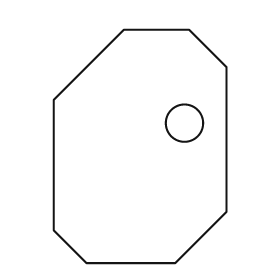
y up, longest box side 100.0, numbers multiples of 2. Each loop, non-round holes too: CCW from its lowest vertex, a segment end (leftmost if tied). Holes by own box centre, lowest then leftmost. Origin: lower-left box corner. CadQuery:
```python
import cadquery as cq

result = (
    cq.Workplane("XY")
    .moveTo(14.0, 0.0)
    .lineTo(52.0, 0.0)
    .lineTo(74.0, 22.0)
    .lineTo(74.0, 84.0)
    .lineTo(58.0, 100.0)
    .lineTo(30.0, 100.0)
    .lineTo(0.0, 70.0)
    .lineTo(0.0, 14.0)
    .close()
    .moveTo(56.0, 60.0)
    .circle(8.0)
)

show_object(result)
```